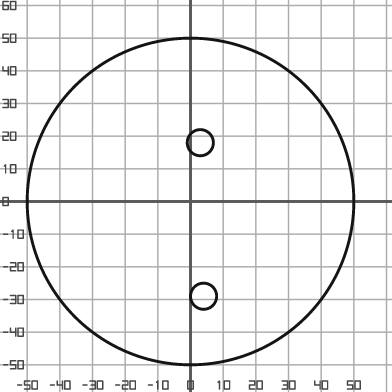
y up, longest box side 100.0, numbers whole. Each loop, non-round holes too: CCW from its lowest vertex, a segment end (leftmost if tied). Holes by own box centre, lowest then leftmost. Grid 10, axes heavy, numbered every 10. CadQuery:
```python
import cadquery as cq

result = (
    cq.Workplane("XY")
    .moveTo(0.0, 0.0)
    .circle(50.0)
    .moveTo(4.0, -29.0)
    .circle(4.0)
    .moveTo(3.0, 18.0)
    .circle(4.0)
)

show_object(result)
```